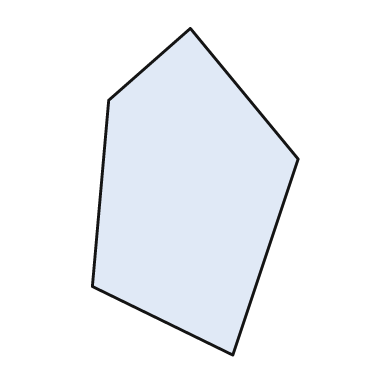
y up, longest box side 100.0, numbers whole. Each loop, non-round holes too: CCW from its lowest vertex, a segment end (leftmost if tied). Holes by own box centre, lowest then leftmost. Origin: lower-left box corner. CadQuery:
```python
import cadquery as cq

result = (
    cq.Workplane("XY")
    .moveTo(43.0, 0.0)
    .lineTo(63.0, 60.0)
    .lineTo(30.0, 100.0)
    .lineTo(5.0, 78.0)
    .lineTo(0.0, 21.0)
    .close()
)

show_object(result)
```